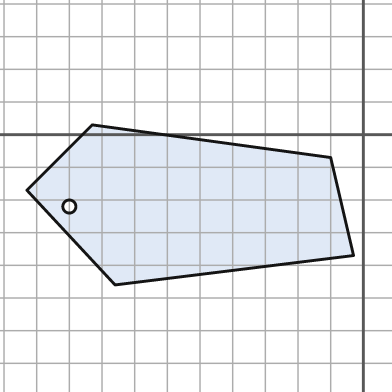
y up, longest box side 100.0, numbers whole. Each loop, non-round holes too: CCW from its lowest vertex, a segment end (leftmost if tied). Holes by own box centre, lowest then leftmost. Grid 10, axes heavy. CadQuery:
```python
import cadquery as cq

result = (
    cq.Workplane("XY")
    .moveTo(-76.0, -46.0)
    .lineTo(-3.0, -37.0)
    .lineTo(-10.0, -7.0)
    .lineTo(-83.0, 3.0)
    .lineTo(-103.0, -17.0)
    .close()
    .moveTo(-90.0, -22.0)
    .circle(2.0)
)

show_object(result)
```